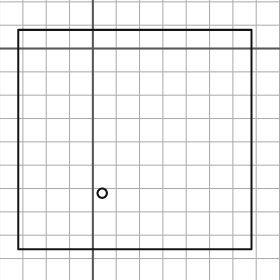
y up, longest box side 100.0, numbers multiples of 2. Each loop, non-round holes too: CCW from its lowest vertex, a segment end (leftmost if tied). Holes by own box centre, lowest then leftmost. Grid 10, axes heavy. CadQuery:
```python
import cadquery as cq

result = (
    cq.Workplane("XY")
    .moveTo(-32.0, -86.0)
    .lineTo(68.0, -86.0)
    .lineTo(68.0, 8.0)
    .lineTo(-32.0, 8.0)
    .close()
    .moveTo(4.0, -62.0)
    .circle(2.0)
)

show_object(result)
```